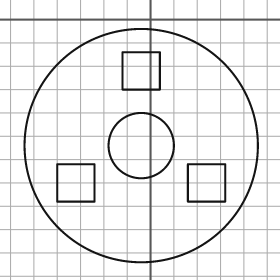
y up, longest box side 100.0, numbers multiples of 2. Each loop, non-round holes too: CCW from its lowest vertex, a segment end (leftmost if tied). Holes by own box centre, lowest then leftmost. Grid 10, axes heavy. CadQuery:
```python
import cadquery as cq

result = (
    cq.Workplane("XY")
    .moveTo(-4.0, -54.0)
    .circle(50.0)
    .moveTo(-40.0, -78.0)
    .lineTo(-24.0, -78.0)
    .lineTo(-24.0, -62.0)
    .lineTo(-40.0, -62.0)
    .close()
    .moveTo(16.0, -78.0)
    .lineTo(32.0, -78.0)
    .lineTo(32.0, -62.0)
    .lineTo(16.0, -62.0)
    .close()
    .moveTo(-4.0, -54.0)
    .circle(14.0)
    .moveTo(-12.0, -30.0)
    .lineTo(4.0, -30.0)
    .lineTo(4.0, -14.0)
    .lineTo(-12.0, -14.0)
    .close()
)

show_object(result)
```